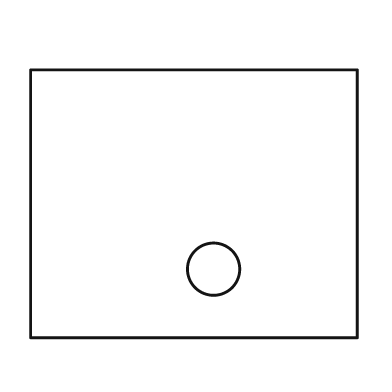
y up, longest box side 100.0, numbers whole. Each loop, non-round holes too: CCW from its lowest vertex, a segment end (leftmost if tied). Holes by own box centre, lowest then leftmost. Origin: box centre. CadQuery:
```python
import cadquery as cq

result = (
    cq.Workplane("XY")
    .moveTo(-50.0, -41.0)
    .lineTo(50.0, -41.0)
    .lineTo(50.0, 41.0)
    .lineTo(-50.0, 41.0)
    .close()
    .moveTo(6.0, -20.0)
    .circle(8.0)
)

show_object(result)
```